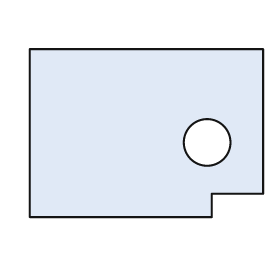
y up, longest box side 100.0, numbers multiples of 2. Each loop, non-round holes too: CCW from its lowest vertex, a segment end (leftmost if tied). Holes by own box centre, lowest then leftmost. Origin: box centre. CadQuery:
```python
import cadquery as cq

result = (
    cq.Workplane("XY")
    .moveTo(-50.0, -36.0)
    .lineTo(28.0, -36.0)
    .lineTo(28.0, -26.0)
    .lineTo(50.0, -26.0)
    .lineTo(50.0, 36.0)
    .lineTo(-50.0, 36.0)
    .close()
    .moveTo(26.0, -4.0)
    .circle(10.0)
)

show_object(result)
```